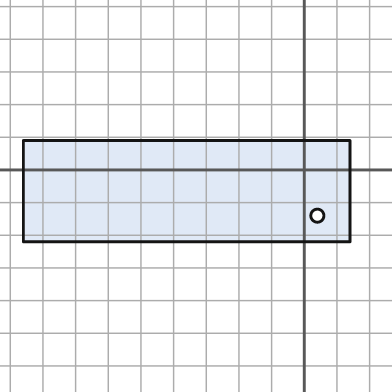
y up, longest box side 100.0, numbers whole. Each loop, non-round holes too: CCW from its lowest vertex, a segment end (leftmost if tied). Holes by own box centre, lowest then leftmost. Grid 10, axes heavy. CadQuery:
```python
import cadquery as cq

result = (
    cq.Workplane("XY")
    .moveTo(-86.0, -22.0)
    .lineTo(14.0, -22.0)
    .lineTo(14.0, 9.0)
    .lineTo(-86.0, 9.0)
    .close()
    .moveTo(4.0, -14.0)
    .circle(2.0)
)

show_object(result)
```